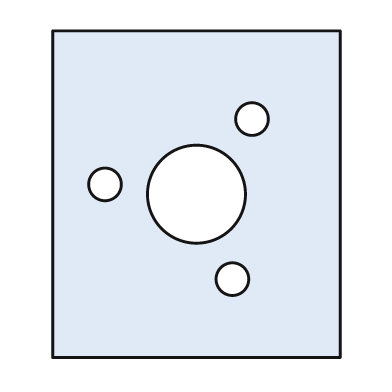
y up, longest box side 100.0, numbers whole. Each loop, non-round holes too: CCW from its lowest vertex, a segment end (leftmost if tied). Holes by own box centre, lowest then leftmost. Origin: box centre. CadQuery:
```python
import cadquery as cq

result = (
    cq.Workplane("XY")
    .moveTo(-44.0, -50.0)
    .lineTo(44.0, -50.0)
    .lineTo(44.0, 50.0)
    .lineTo(-44.0, 50.0)
    .close()
    .moveTo(11.0, -26.0)
    .circle(5.0)
    .moveTo(0.0, 0.0)
    .circle(15.0)
    .moveTo(-28.0, 3.0)
    .circle(5.0)
    .moveTo(17.0, 23.0)
    .circle(5.0)
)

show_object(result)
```